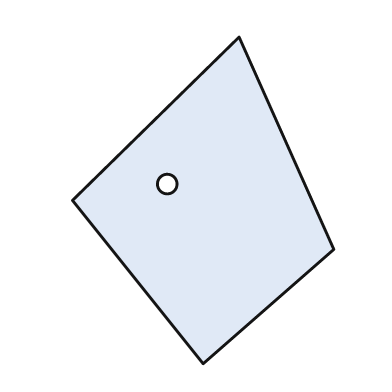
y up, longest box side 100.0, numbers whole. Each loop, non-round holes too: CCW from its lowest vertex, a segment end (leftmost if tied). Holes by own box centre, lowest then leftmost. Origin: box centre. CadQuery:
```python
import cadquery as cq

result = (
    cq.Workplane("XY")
    .moveTo(0.0, -50.0)
    .lineTo(40.0, -15.0)
    .lineTo(11.0, 50.0)
    .lineTo(-40.0, 0.0)
    .close()
    .moveTo(-11.0, 5.0)
    .circle(3.0)
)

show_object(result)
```